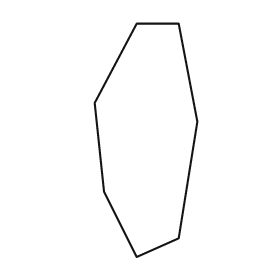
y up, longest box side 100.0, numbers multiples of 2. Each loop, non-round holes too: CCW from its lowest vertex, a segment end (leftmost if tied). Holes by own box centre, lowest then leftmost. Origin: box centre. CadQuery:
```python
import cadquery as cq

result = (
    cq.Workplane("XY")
    .moveTo(-4.0, -50.0)
    .lineTo(14.0, -42.0)
    .lineTo(22.0, 8.0)
    .lineTo(14.0, 50.0)
    .lineTo(-4.0, 50.0)
    .lineTo(-22.0, 16.0)
    .lineTo(-18.0, -22.0)
    .close()
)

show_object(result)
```